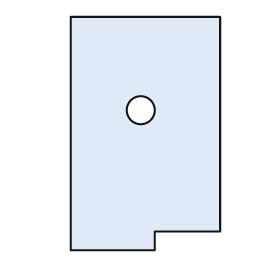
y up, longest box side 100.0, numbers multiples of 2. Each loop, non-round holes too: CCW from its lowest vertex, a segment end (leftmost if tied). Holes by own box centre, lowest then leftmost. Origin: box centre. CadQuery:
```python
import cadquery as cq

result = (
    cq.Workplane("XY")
    .moveTo(-32.0, -50.0)
    .lineTo(4.0, -50.0)
    .lineTo(4.0, -42.0)
    .lineTo(32.0, -42.0)
    .lineTo(32.0, 50.0)
    .lineTo(-32.0, 50.0)
    .close()
    .moveTo(-2.0, 10.0)
    .circle(6.0)
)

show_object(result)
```